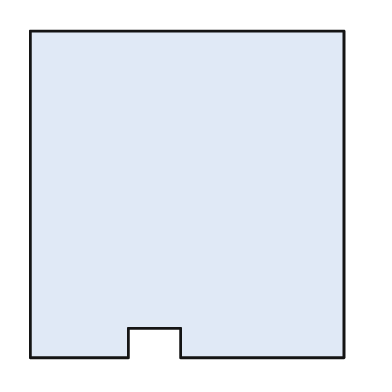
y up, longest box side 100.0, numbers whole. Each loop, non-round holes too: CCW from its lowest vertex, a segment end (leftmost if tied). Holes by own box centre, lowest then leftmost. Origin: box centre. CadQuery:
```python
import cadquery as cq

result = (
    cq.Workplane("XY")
    .moveTo(-48.0, -50.0)
    .lineTo(-18.0, -50.0)
    .lineTo(-18.0, -41.0)
    .lineTo(-2.0, -41.0)
    .lineTo(-2.0, -50.0)
    .lineTo(48.0, -50.0)
    .lineTo(48.0, 50.0)
    .lineTo(-48.0, 50.0)
    .close()
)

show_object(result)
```